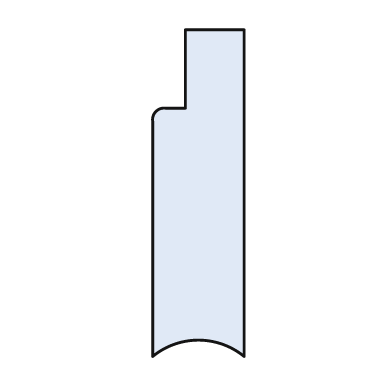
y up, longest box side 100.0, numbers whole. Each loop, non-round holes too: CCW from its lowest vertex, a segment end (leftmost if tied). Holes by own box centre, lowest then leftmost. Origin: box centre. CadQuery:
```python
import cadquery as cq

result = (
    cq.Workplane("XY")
    .moveTo(-14.0, -50.0)
    .threePointArc((0.0, -45.0), (14.0, -50.0))
    .lineTo(14.0, 50.0)
    .lineTo(-4.0, 50.0)
    .lineTo(-4.0, 26.0)
    .lineTo(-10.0, 26.0)
    .threePointArc((-13.0, 25.0), (-14.0, 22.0))
    .close()
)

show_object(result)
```